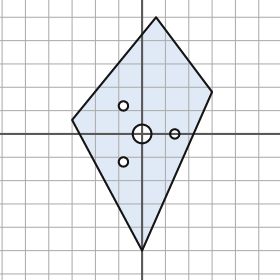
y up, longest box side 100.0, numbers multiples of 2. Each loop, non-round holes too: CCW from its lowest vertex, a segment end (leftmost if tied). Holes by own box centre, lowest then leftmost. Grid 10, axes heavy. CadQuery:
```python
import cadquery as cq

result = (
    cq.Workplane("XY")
    .moveTo(0.0, -50.0)
    .lineTo(30.0, 18.0)
    .lineTo(6.0, 50.0)
    .lineTo(-30.0, 6.0)
    .close()
    .moveTo(-8.0, -12.0)
    .circle(2.0)
    .moveTo(0.0, 0.0)
    .circle(4.0)
    .moveTo(14.0, 0.0)
    .circle(2.0)
    .moveTo(-8.0, 12.0)
    .circle(2.0)
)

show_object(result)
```